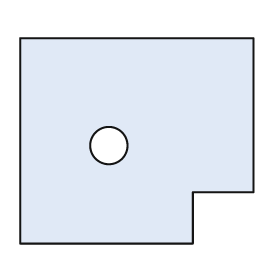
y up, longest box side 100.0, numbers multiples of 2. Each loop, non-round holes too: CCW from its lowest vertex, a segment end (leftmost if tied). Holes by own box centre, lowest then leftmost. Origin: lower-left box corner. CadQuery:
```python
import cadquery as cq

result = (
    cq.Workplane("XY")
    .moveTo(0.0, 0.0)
    .lineTo(74.0, 0.0)
    .lineTo(74.0, 22.0)
    .lineTo(100.0, 22.0)
    .lineTo(100.0, 88.0)
    .lineTo(0.0, 88.0)
    .close()
    .moveTo(38.0, 42.0)
    .circle(8.0)
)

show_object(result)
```